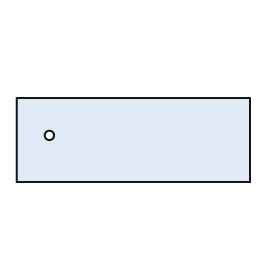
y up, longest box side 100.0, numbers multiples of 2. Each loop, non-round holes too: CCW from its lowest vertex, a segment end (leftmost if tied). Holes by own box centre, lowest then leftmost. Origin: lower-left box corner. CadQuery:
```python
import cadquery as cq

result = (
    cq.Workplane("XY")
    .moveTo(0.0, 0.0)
    .lineTo(100.0, 0.0)
    .lineTo(100.0, 36.0)
    .lineTo(0.0, 36.0)
    .close()
    .moveTo(14.0, 20.0)
    .circle(2.0)
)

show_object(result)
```